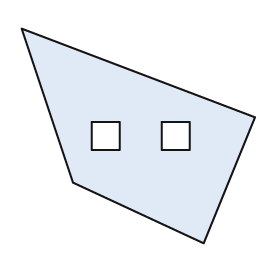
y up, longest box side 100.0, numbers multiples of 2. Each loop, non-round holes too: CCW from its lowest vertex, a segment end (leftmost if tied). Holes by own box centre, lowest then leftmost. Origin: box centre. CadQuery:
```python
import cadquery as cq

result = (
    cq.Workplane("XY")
    .moveTo(28.0, -46.0)
    .lineTo(50.0, 8.0)
    .lineTo(-50.0, 46.0)
    .lineTo(-28.0, -20.0)
    .close()
    .moveTo(-20.0, -6.0)
    .lineTo(-8.0, -6.0)
    .lineTo(-8.0, 6.0)
    .lineTo(-20.0, 6.0)
    .close()
    .moveTo(10.0, -6.0)
    .lineTo(22.0, -6.0)
    .lineTo(22.0, 6.0)
    .lineTo(10.0, 6.0)
    .close()
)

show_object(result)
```